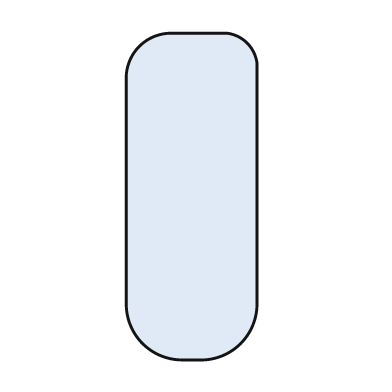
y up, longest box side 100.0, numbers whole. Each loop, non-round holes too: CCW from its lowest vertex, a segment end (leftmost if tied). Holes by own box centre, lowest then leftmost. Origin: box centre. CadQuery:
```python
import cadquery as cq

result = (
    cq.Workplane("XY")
    .moveTo(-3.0, -50.0)
    .lineTo(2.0, -50.0)
    .threePointArc((15.0, -45.0), (20.0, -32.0))
    .lineTo(20.0, 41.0)
    .threePointArc((17.0, 47.0), (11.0, 50.0))
    .lineTo(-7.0, 50.0)
    .threePointArc((-16.0, 46.0), (-20.0, 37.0))
    .lineTo(-20.0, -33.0)
    .threePointArc((-15.0, -45.0), (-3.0, -50.0))
    .close()
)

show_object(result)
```